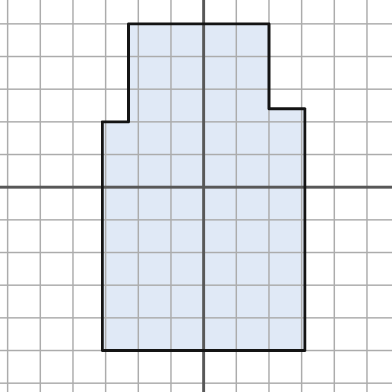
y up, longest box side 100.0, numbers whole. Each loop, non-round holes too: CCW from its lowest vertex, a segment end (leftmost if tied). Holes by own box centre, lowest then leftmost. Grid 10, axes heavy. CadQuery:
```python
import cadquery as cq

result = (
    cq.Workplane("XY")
    .moveTo(-31.0, -50.0)
    .lineTo(31.0, -50.0)
    .lineTo(31.0, 24.0)
    .lineTo(20.0, 24.0)
    .lineTo(20.0, 50.0)
    .lineTo(-23.0, 50.0)
    .lineTo(-23.0, 20.0)
    .lineTo(-31.0, 20.0)
    .close()
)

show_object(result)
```